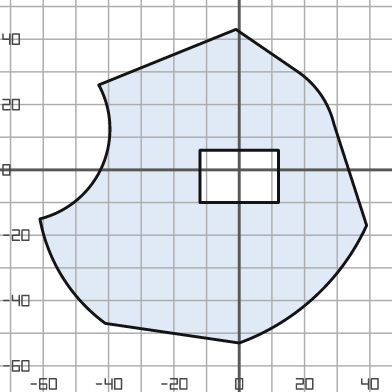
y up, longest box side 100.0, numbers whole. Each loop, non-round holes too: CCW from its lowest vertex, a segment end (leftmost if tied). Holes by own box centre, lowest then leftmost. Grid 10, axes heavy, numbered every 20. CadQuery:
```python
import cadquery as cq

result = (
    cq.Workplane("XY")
    .moveTo(0.0, -53.0)
    .threePointArc((23.0, -39.0), (39.0, -17.0))
    .lineTo(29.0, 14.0)
    .threePointArc((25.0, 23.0), (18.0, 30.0))
    .lineTo(-1.0, 43.0)
    .lineTo(-43.0, 26.0)
    .threePointArc((-42.0, 1.0), (-61.0, -15.0))
    .threePointArc((-54.0, -33.0), (-41.0, -47.0))
    .close()
    .moveTo(-12.0, -10.0)
    .lineTo(12.0, -10.0)
    .lineTo(12.0, 6.0)
    .lineTo(-12.0, 6.0)
    .close()
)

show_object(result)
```